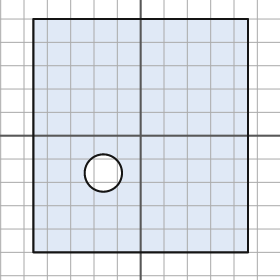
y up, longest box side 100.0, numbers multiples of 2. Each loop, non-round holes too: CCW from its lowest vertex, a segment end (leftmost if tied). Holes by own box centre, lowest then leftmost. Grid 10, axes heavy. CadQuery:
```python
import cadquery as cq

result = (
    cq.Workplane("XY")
    .moveTo(-46.0, -50.0)
    .lineTo(46.0, -50.0)
    .lineTo(46.0, 50.0)
    .lineTo(-46.0, 50.0)
    .close()
    .moveTo(-16.0, -16.0)
    .circle(8.0)
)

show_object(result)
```